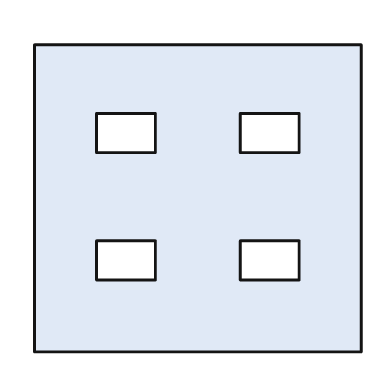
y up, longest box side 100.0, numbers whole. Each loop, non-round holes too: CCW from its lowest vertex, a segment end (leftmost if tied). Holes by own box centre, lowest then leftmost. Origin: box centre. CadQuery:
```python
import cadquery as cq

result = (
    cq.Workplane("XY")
    .moveTo(-50.0, -47.0)
    .lineTo(50.0, -47.0)
    .lineTo(50.0, 47.0)
    .lineTo(-50.0, 47.0)
    .close()
    .moveTo(-31.0, -25.0)
    .lineTo(-13.0, -25.0)
    .lineTo(-13.0, -13.0)
    .lineTo(-31.0, -13.0)
    .close()
    .moveTo(13.0, -25.0)
    .lineTo(31.0, -25.0)
    .lineTo(31.0, -13.0)
    .lineTo(13.0, -13.0)
    .close()
    .moveTo(-31.0, 14.0)
    .lineTo(-13.0, 14.0)
    .lineTo(-13.0, 26.0)
    .lineTo(-31.0, 26.0)
    .close()
    .moveTo(13.0, 14.0)
    .lineTo(31.0, 14.0)
    .lineTo(31.0, 26.0)
    .lineTo(13.0, 26.0)
    .close()
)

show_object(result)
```